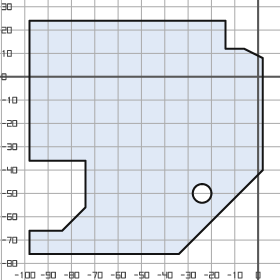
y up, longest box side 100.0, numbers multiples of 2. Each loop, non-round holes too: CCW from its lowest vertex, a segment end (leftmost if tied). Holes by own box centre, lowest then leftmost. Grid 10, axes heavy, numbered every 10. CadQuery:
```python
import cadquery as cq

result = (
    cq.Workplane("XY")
    .moveTo(-98.0, -76.0)
    .lineTo(-34.0, -76.0)
    .lineTo(2.0, -40.0)
    .lineTo(2.0, 8.0)
    .lineTo(-6.0, 12.0)
    .lineTo(-14.0, 12.0)
    .lineTo(-14.0, 24.0)
    .lineTo(-98.0, 24.0)
    .lineTo(-98.0, -36.0)
    .lineTo(-74.0, -36.0)
    .lineTo(-74.0, -56.0)
    .lineTo(-84.0, -66.0)
    .lineTo(-98.0, -66.0)
    .close()
    .moveTo(-24.0, -50.0)
    .circle(4.0)
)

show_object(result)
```